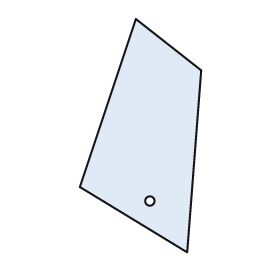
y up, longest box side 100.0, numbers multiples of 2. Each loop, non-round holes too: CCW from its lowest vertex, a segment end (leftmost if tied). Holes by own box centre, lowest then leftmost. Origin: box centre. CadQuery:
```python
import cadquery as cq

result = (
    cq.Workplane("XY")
    .moveTo(20.0, -50.0)
    .lineTo(26.0, 28.0)
    .lineTo(-2.0, 50.0)
    .lineTo(-26.0, -22.0)
    .close()
    .moveTo(4.0, -28.0)
    .circle(2.0)
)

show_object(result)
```